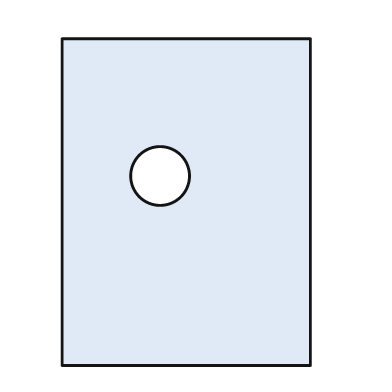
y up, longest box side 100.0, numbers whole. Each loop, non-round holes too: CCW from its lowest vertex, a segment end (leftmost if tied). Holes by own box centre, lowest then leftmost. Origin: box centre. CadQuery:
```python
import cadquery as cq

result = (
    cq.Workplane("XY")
    .moveTo(-38.0, -50.0)
    .lineTo(38.0, -50.0)
    .lineTo(38.0, 50.0)
    .lineTo(-38.0, 50.0)
    .close()
    .moveTo(-8.0, 8.0)
    .circle(9.0)
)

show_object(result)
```